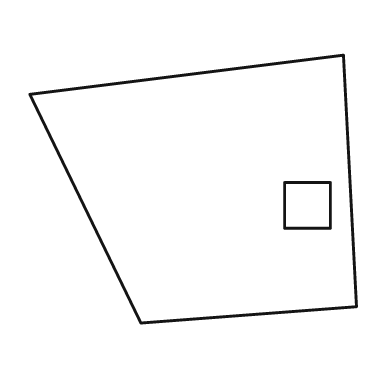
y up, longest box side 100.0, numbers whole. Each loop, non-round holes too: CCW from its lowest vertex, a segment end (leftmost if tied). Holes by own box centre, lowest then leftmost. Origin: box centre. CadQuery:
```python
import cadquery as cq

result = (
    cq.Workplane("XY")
    .moveTo(-16.0, -41.0)
    .lineTo(50.0, -36.0)
    .lineTo(46.0, 41.0)
    .lineTo(-50.0, 29.0)
    .close()
    .moveTo(28.0, -12.0)
    .lineTo(42.0, -12.0)
    .lineTo(42.0, 2.0)
    .lineTo(28.0, 2.0)
    .close()
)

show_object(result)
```